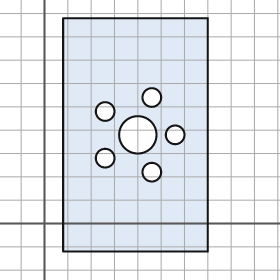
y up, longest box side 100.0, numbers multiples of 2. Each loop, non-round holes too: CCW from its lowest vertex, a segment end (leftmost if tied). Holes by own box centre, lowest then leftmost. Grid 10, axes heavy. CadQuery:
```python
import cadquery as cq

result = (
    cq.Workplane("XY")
    .moveTo(8.0, -12.0)
    .lineTo(70.0, -12.0)
    .lineTo(70.0, 88.0)
    .lineTo(8.0, 88.0)
    .close()
    .moveTo(46.0, 22.0)
    .circle(4.0)
    .moveTo(26.0, 28.0)
    .circle(4.0)
    .moveTo(40.0, 38.0)
    .circle(8.0)
    .moveTo(56.0, 38.0)
    .circle(4.0)
    .moveTo(26.0, 48.0)
    .circle(4.0)
    .moveTo(46.0, 54.0)
    .circle(4.0)
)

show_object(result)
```